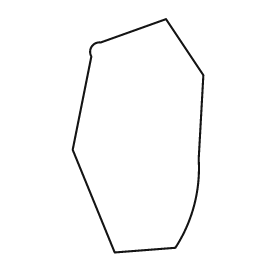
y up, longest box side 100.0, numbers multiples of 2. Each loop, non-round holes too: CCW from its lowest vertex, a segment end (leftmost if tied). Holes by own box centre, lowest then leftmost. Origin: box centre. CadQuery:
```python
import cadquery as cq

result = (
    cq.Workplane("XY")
    .moveTo(-10.0, -50.0)
    .lineTo(16.0, -48.0)
    .threePointArc((24.0, -30.0), (26.0, -10.0))
    .lineTo(28.0, 26.0)
    .lineTo(12.0, 50.0)
    .lineTo(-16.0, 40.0)
    .threePointArc((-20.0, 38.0), (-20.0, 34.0))
    .lineTo(-28.0, -6.0)
    .close()
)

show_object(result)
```